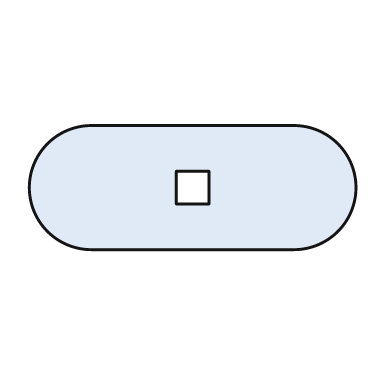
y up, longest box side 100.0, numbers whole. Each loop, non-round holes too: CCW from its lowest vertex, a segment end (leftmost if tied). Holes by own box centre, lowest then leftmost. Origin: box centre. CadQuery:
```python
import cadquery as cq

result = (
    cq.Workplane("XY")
    .moveTo(-31.0, -19.0)
    .lineTo(31.0, -19.0)
    .threePointArc((50.0, 0.0), (31.0, 19.0))
    .lineTo(-31.0, 19.0)
    .threePointArc((-50.0, 0.0), (-31.0, -19.0))
    .close()
    .moveTo(-5.0, -5.0)
    .lineTo(5.0, -5.0)
    .lineTo(5.0, 5.0)
    .lineTo(-5.0, 5.0)
    .close()
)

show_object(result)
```